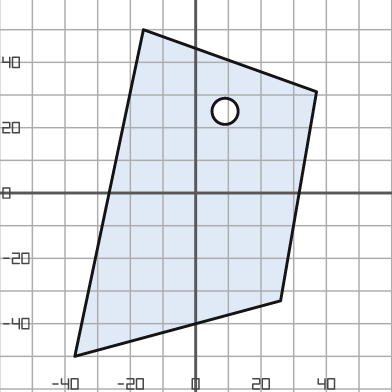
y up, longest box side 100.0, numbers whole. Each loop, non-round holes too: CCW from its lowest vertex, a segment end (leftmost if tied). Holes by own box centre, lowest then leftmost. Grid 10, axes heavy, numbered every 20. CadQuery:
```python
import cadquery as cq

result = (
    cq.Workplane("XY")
    .moveTo(-37.0, -50.0)
    .lineTo(26.0, -33.0)
    .lineTo(37.0, 31.0)
    .lineTo(-16.0, 50.0)
    .close()
    .moveTo(9.0, 25.0)
    .circle(4.0)
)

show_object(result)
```